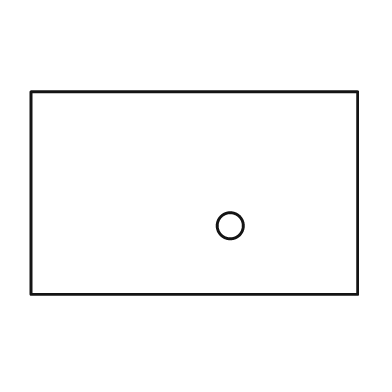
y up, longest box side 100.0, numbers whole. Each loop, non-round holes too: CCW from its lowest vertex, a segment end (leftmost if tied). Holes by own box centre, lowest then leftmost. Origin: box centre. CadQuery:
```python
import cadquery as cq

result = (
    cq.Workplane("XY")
    .moveTo(-50.0, -31.0)
    .lineTo(50.0, -31.0)
    .lineTo(50.0, 31.0)
    .lineTo(-50.0, 31.0)
    .close()
    .moveTo(11.0, -10.0)
    .circle(4.0)
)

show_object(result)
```